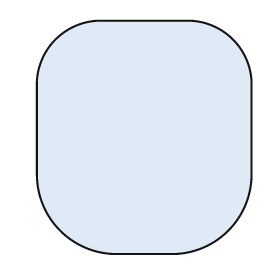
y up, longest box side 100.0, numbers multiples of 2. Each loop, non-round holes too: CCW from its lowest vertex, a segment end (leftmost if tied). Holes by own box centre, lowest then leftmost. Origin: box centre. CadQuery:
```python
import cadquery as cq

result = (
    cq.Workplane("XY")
    .moveTo(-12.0, -50.0)
    .lineTo(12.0, -50.0)
    .threePointArc((36.0, -40.0), (46.0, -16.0))
    .lineTo(46.0, 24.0)
    .threePointArc((38.0, 42.0), (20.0, 50.0))
    .lineTo(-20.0, 50.0)
    .threePointArc((-38.0, 42.0), (-46.0, 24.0))
    .lineTo(-46.0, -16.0)
    .threePointArc((-36.0, -40.0), (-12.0, -50.0))
    .close()
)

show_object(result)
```